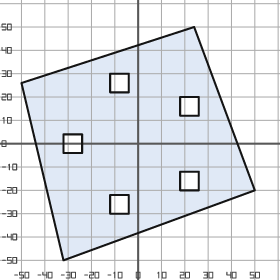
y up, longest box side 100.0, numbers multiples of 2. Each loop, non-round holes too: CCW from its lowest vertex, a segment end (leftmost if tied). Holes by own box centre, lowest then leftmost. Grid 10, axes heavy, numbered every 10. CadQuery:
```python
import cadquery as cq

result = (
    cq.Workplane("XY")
    .moveTo(-32.0, -50.0)
    .lineTo(50.0, -20.0)
    .lineTo(24.0, 50.0)
    .lineTo(-50.0, 26.0)
    .close()
    .moveTo(-12.0, -30.0)
    .lineTo(-4.0, -30.0)
    .lineTo(-4.0, -22.0)
    .lineTo(-12.0, -22.0)
    .close()
    .moveTo(18.0, -20.0)
    .lineTo(26.0, -20.0)
    .lineTo(26.0, -12.0)
    .lineTo(18.0, -12.0)
    .close()
    .moveTo(-32.0, -4.0)
    .lineTo(-24.0, -4.0)
    .lineTo(-24.0, 4.0)
    .lineTo(-32.0, 4.0)
    .close()
    .moveTo(18.0, 12.0)
    .lineTo(26.0, 12.0)
    .lineTo(26.0, 20.0)
    .lineTo(18.0, 20.0)
    .close()
    .moveTo(-12.0, 22.0)
    .lineTo(-4.0, 22.0)
    .lineTo(-4.0, 30.0)
    .lineTo(-12.0, 30.0)
    .close()
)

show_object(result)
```